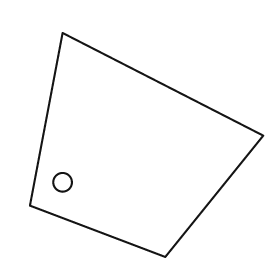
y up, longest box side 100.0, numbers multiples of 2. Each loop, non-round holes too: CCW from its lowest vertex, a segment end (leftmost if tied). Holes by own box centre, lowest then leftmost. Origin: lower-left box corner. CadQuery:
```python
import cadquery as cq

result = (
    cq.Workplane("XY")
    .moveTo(58.0, 0.0)
    .lineTo(100.0, 52.0)
    .lineTo(14.0, 96.0)
    .lineTo(0.0, 22.0)
    .close()
    .moveTo(14.0, 32.0)
    .circle(4.0)
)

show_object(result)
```